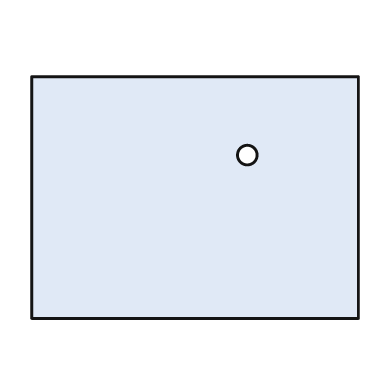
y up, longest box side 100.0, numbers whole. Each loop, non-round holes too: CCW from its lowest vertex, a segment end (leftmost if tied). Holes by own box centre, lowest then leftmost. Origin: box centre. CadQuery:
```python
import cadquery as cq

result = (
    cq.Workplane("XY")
    .moveTo(-50.0, -37.0)
    .lineTo(50.0, -37.0)
    .lineTo(50.0, 37.0)
    .lineTo(-50.0, 37.0)
    .close()
    .moveTo(16.0, 13.0)
    .circle(3.0)
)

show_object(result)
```